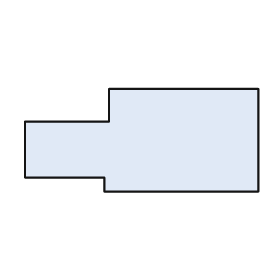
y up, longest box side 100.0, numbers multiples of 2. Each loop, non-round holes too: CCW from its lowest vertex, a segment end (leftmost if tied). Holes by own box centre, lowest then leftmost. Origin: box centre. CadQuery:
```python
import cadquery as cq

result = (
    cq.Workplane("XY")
    .moveTo(-16.0, -22.0)
    .lineTo(50.0, -22.0)
    .lineTo(50.0, 22.0)
    .lineTo(-14.0, 22.0)
    .lineTo(-14.0, 8.0)
    .lineTo(-50.0, 8.0)
    .lineTo(-50.0, -16.0)
    .lineTo(-16.0, -16.0)
    .close()
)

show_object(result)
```